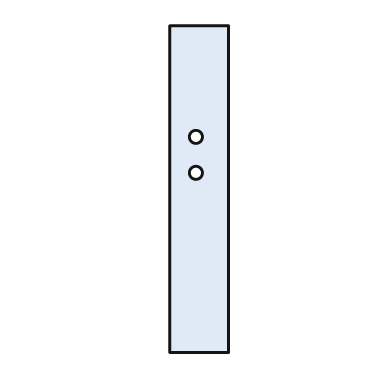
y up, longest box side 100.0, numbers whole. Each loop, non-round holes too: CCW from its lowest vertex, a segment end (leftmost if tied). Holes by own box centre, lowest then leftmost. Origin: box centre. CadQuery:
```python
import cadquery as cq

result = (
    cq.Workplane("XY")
    .moveTo(-9.0, -50.0)
    .lineTo(9.0, -50.0)
    .lineTo(9.0, 50.0)
    .lineTo(-9.0, 50.0)
    .close()
    .moveTo(-1.0, 5.0)
    .circle(2.0)
    .moveTo(-1.0, 16.0)
    .circle(2.0)
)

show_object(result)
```